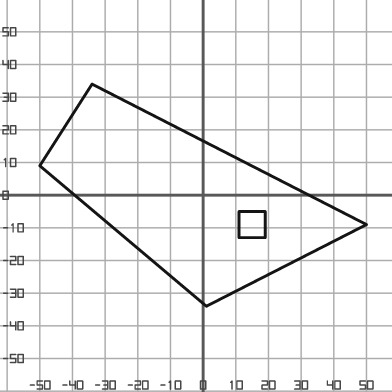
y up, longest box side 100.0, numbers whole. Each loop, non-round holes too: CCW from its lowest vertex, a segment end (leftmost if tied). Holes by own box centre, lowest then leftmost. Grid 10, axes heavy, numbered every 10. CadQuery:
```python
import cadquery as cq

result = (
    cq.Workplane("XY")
    .moveTo(1.0, -34.0)
    .lineTo(50.0, -9.0)
    .lineTo(-34.0, 34.0)
    .lineTo(-50.0, 9.0)
    .close()
    .moveTo(11.0, -13.0)
    .lineTo(19.0, -13.0)
    .lineTo(19.0, -5.0)
    .lineTo(11.0, -5.0)
    .close()
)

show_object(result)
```